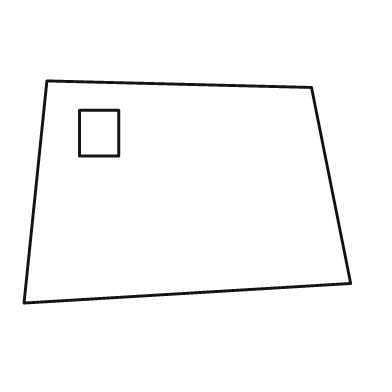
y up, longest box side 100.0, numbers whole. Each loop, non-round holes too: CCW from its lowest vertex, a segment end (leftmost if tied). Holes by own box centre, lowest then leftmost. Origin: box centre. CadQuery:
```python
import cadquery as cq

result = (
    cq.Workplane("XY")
    .moveTo(-50.0, -34.0)
    .lineTo(50.0, -28.0)
    .lineTo(38.0, 32.0)
    .lineTo(-43.0, 34.0)
    .close()
    .moveTo(-33.0, 11.0)
    .lineTo(-21.0, 11.0)
    .lineTo(-21.0, 25.0)
    .lineTo(-33.0, 25.0)
    .close()
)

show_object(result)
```